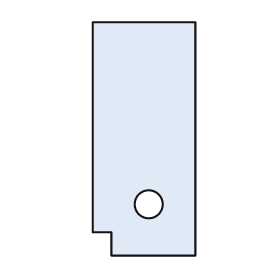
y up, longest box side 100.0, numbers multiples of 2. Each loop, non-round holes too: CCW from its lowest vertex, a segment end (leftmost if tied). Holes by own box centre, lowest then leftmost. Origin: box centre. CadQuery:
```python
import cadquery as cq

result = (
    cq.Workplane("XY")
    .moveTo(-14.0, -50.0)
    .lineTo(22.0, -50.0)
    .lineTo(22.0, 50.0)
    .lineTo(-22.0, 50.0)
    .lineTo(-22.0, -40.0)
    .lineTo(-14.0, -40.0)
    .close()
    .moveTo(2.0, -28.0)
    .circle(6.0)
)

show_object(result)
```